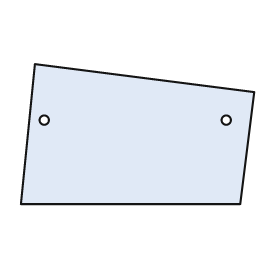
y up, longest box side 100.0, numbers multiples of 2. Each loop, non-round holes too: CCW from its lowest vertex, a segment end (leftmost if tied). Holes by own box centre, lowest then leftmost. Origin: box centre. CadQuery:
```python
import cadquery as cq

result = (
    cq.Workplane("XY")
    .moveTo(-50.0, -30.0)
    .lineTo(44.0, -30.0)
    .lineTo(50.0, 18.0)
    .lineTo(-44.0, 30.0)
    .close()
    .moveTo(-40.0, 6.0)
    .circle(2.0)
    .moveTo(38.0, 6.0)
    .circle(2.0)
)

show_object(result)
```